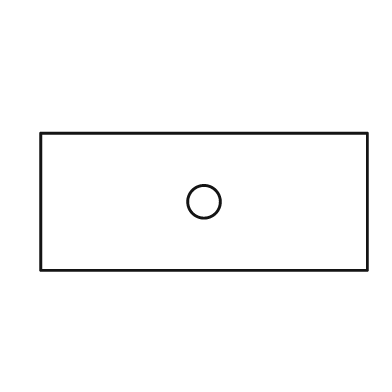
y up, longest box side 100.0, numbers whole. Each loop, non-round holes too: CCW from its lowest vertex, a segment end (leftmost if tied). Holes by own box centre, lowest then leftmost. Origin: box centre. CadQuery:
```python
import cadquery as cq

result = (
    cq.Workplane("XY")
    .moveTo(-50.0, -21.0)
    .lineTo(50.0, -21.0)
    .lineTo(50.0, 21.0)
    .lineTo(-50.0, 21.0)
    .close()
    .moveTo(0.0, 0.0)
    .circle(5.0)
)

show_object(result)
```